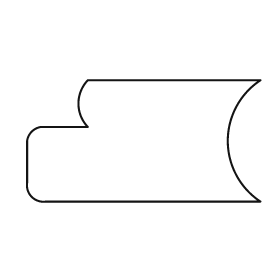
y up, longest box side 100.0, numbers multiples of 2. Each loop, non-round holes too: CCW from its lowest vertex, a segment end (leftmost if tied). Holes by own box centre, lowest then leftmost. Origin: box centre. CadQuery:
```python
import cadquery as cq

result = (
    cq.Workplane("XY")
    .moveTo(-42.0, -26.0)
    .lineTo(50.0, -26.0)
    .threePointArc((36.0, 0.0), (50.0, 26.0))
    .lineTo(-24.0, 26.0)
    .threePointArc((-28.0, 16.0), (-24.0, 6.0))
    .lineTo(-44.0, 6.0)
    .threePointArc((-48.0, 4.0), (-50.0, 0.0))
    .lineTo(-50.0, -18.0)
    .threePointArc((-48.0, -24.0), (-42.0, -26.0))
    .close()
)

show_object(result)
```